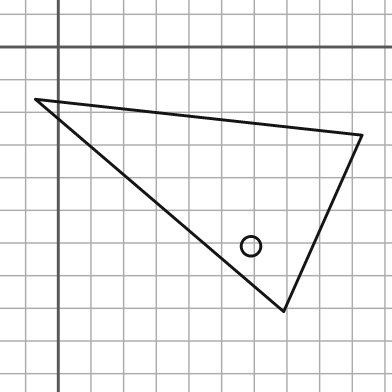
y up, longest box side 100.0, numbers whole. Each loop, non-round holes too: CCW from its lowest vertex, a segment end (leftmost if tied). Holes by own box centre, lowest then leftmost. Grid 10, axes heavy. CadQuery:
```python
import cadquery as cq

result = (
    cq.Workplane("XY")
    .moveTo(69.0, -81.0)
    .lineTo(93.0, -27.0)
    .lineTo(-7.0, -16.0)
    .close()
    .moveTo(59.0, -61.0)
    .circle(3.0)
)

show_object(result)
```